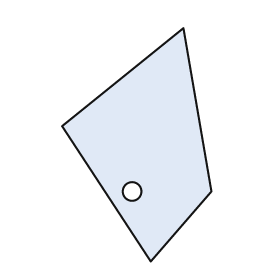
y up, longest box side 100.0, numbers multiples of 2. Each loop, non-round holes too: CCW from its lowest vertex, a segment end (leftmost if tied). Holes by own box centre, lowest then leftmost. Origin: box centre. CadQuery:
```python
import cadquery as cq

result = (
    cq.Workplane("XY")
    .moveTo(6.0, -50.0)
    .lineTo(32.0, -20.0)
    .lineTo(20.0, 50.0)
    .lineTo(-32.0, 8.0)
    .close()
    .moveTo(-2.0, -20.0)
    .circle(4.0)
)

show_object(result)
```